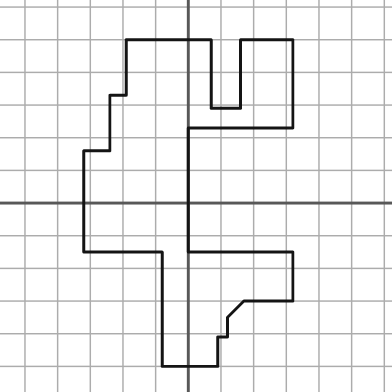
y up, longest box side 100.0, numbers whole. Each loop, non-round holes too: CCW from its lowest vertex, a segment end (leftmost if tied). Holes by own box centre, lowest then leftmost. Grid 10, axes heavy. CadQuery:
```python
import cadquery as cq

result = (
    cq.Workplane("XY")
    .moveTo(-8.0, -50.0)
    .lineTo(9.0, -50.0)
    .lineTo(9.0, -41.0)
    .lineTo(12.0, -41.0)
    .lineTo(12.0, -35.0)
    .lineTo(17.0, -30.0)
    .lineTo(32.0, -30.0)
    .lineTo(32.0, -15.0)
    .lineTo(0.0, -15.0)
    .lineTo(0.0, 23.0)
    .lineTo(32.0, 23.0)
    .lineTo(32.0, 50.0)
    .lineTo(16.0, 50.0)
    .lineTo(16.0, 29.0)
    .lineTo(7.0, 29.0)
    .lineTo(7.0, 50.0)
    .lineTo(-19.0, 50.0)
    .lineTo(-19.0, 33.0)
    .lineTo(-24.0, 33.0)
    .lineTo(-24.0, 16.0)
    .lineTo(-32.0, 16.0)
    .lineTo(-32.0, -15.0)
    .lineTo(-8.0, -15.0)
    .close()
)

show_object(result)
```